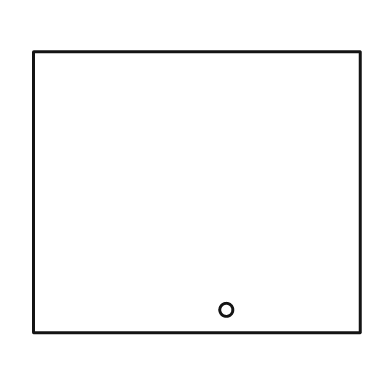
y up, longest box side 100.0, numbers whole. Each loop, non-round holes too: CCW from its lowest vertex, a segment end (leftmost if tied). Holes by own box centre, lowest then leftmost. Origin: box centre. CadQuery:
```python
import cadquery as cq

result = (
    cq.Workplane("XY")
    .moveTo(-50.0, -43.0)
    .lineTo(50.0, -43.0)
    .lineTo(50.0, 43.0)
    .lineTo(-50.0, 43.0)
    .close()
    .moveTo(9.0, -36.0)
    .circle(2.0)
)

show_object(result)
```